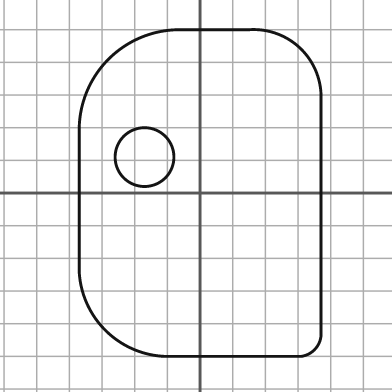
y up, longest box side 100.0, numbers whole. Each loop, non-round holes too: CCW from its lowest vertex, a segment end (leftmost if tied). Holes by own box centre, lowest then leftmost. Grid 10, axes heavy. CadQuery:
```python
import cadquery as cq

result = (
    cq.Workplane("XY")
    .moveTo(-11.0, -50.0)
    .lineTo(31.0, -50.0)
    .threePointArc((35.0, -48.0), (37.0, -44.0))
    .lineTo(37.0, 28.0)
    .threePointArc((31.0, 44.0), (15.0, 50.0))
    .lineTo(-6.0, 50.0)
    .threePointArc((-28.0, 41.0), (-37.0, 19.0))
    .lineTo(-37.0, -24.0)
    .threePointArc((-29.0, -42.0), (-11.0, -50.0))
    .close()
    .moveTo(-17.0, 11.0)
    .circle(9.0)
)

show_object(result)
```